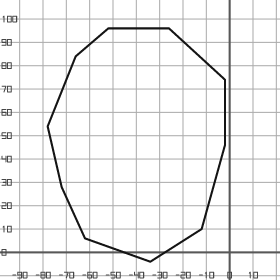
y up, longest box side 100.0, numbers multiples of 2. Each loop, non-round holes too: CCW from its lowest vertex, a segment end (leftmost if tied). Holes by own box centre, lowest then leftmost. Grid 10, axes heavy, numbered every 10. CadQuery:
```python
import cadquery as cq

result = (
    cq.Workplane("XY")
    .moveTo(-34.0, -4.0)
    .lineTo(-12.0, 10.0)
    .lineTo(-2.0, 46.0)
    .lineTo(-2.0, 74.0)
    .lineTo(-26.0, 96.0)
    .lineTo(-52.0, 96.0)
    .lineTo(-66.0, 84.0)
    .lineTo(-78.0, 54.0)
    .lineTo(-72.0, 28.0)
    .lineTo(-62.0, 6.0)
    .close()
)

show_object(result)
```